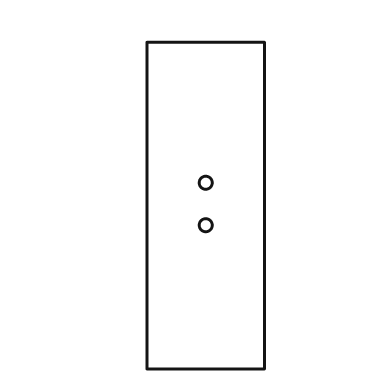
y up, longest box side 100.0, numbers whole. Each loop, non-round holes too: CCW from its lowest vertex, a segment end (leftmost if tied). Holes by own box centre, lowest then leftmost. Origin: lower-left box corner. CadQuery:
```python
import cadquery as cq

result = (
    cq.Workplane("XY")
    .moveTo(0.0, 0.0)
    .lineTo(36.0, 0.0)
    .lineTo(36.0, 100.0)
    .lineTo(0.0, 100.0)
    .close()
    .moveTo(18.0, 44.0)
    .circle(2.0)
    .moveTo(18.0, 57.0)
    .circle(2.0)
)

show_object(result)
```